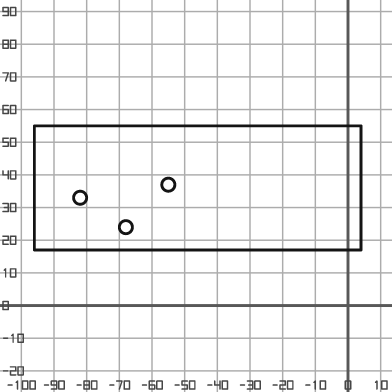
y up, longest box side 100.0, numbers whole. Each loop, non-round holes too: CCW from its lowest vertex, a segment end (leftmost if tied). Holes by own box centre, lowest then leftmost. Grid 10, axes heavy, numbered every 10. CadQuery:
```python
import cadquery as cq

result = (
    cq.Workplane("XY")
    .moveTo(-96.0, 17.0)
    .lineTo(4.0, 17.0)
    .lineTo(4.0, 55.0)
    .lineTo(-96.0, 55.0)
    .close()
    .moveTo(-68.0, 24.0)
    .circle(2.0)
    .moveTo(-82.0, 33.0)
    .circle(2.0)
    .moveTo(-55.0, 37.0)
    .circle(2.0)
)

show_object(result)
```